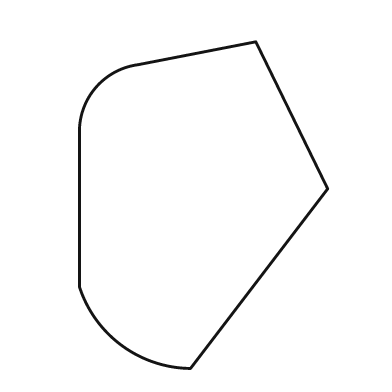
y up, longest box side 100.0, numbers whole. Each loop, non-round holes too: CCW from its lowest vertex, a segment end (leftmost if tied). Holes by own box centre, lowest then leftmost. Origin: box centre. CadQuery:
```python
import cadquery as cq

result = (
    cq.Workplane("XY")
    .moveTo(-4.0, -50.0)
    .lineTo(38.0, 5.0)
    .lineTo(16.0, 50.0)
    .lineTo(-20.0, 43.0)
    .threePointArc((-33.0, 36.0), (-38.0, 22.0))
    .lineTo(-38.0, -25.0)
    .threePointArc((-25.0, -43.0), (-4.0, -50.0))
    .close()
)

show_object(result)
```